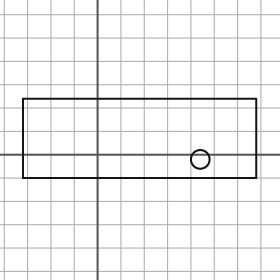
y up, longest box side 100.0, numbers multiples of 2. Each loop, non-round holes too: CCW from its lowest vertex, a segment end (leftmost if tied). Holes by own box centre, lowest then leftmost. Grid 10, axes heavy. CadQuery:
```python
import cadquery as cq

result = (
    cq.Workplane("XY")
    .moveTo(-32.0, -10.0)
    .lineTo(68.0, -10.0)
    .lineTo(68.0, 24.0)
    .lineTo(-32.0, 24.0)
    .close()
    .moveTo(44.0, -2.0)
    .circle(4.0)
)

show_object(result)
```